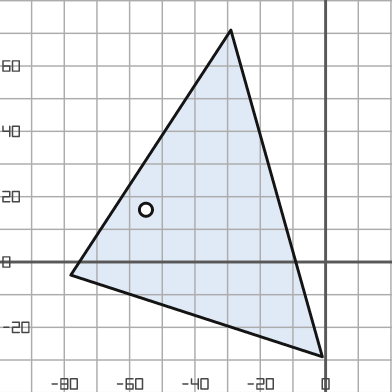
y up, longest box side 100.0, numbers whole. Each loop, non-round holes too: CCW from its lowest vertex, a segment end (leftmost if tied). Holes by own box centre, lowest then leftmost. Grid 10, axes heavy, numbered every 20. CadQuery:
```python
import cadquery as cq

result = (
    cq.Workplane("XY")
    .moveTo(-1.0, -29.0)
    .lineTo(-29.0, 71.0)
    .lineTo(-78.0, -4.0)
    .close()
    .moveTo(-55.0, 16.0)
    .circle(2.0)
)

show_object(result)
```